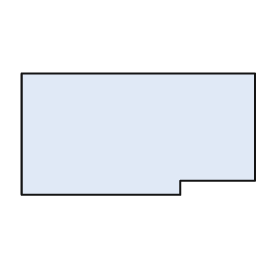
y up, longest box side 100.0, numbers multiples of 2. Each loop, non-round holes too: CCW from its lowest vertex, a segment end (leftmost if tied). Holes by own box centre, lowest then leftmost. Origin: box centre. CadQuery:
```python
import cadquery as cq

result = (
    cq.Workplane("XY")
    .moveTo(-50.0, -26.0)
    .lineTo(18.0, -26.0)
    .lineTo(18.0, -20.0)
    .lineTo(50.0, -20.0)
    .lineTo(50.0, 26.0)
    .lineTo(-50.0, 26.0)
    .close()
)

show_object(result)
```